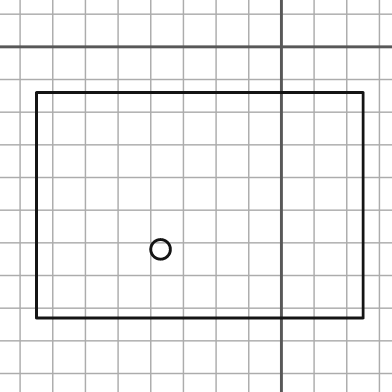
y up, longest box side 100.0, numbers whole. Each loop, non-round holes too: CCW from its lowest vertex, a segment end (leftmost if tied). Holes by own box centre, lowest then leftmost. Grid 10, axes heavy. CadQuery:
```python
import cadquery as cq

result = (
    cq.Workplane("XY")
    .moveTo(-75.0, -83.0)
    .lineTo(25.0, -83.0)
    .lineTo(25.0, -14.0)
    .lineTo(-75.0, -14.0)
    .close()
    .moveTo(-37.0, -62.0)
    .circle(3.0)
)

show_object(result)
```